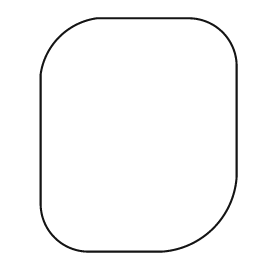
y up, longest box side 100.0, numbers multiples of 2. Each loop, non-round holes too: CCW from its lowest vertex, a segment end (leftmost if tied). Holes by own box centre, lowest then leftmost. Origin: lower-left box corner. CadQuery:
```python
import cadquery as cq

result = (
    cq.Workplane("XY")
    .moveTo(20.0, 0.0)
    .lineTo(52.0, 0.0)
    .threePointArc((74.0, 10.0), (84.0, 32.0))
    .lineTo(84.0, 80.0)
    .threePointArc((78.0, 94.0), (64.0, 100.0))
    .lineTo(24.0, 100.0)
    .threePointArc((8.0, 92.0), (0.0, 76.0))
    .lineTo(0.0, 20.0)
    .threePointArc((6.0, 6.0), (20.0, 0.0))
    .close()
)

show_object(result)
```